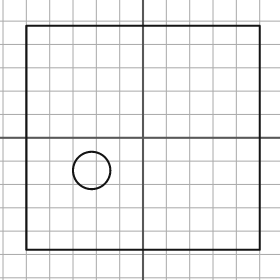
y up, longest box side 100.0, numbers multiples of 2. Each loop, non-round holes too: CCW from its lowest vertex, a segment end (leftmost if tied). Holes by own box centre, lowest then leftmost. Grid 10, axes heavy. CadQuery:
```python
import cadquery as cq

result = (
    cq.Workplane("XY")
    .moveTo(-50.0, -48.0)
    .lineTo(50.0, -48.0)
    .lineTo(50.0, 48.0)
    .lineTo(-50.0, 48.0)
    .close()
    .moveTo(-22.0, -14.0)
    .circle(8.0)
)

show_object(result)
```